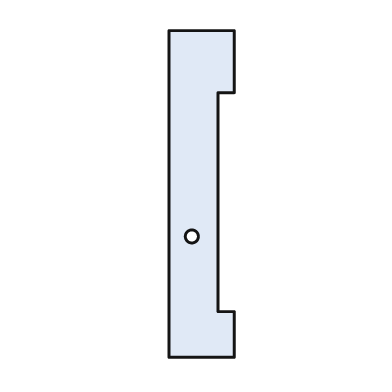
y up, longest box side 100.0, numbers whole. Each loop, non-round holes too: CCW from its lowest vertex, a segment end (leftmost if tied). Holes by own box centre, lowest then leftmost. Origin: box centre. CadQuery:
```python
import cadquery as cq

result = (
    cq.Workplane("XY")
    .moveTo(-10.0, -50.0)
    .lineTo(10.0, -50.0)
    .lineTo(10.0, -36.0)
    .lineTo(5.0, -36.0)
    .lineTo(5.0, 31.0)
    .lineTo(10.0, 31.0)
    .lineTo(10.0, 50.0)
    .lineTo(-10.0, 50.0)
    .close()
    .moveTo(-3.0, -13.0)
    .circle(2.0)
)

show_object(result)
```